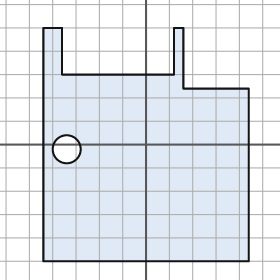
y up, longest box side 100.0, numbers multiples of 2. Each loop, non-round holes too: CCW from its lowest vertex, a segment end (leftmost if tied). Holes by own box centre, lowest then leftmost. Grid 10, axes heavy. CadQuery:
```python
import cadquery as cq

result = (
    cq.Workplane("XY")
    .moveTo(-44.0, -50.0)
    .lineTo(44.0, -50.0)
    .lineTo(44.0, 24.0)
    .lineTo(16.0, 24.0)
    .lineTo(16.0, 50.0)
    .lineTo(12.0, 50.0)
    .lineTo(12.0, 30.0)
    .lineTo(-36.0, 30.0)
    .lineTo(-36.0, 50.0)
    .lineTo(-44.0, 50.0)
    .close()
    .moveTo(-34.0, -2.0)
    .circle(6.0)
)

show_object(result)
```